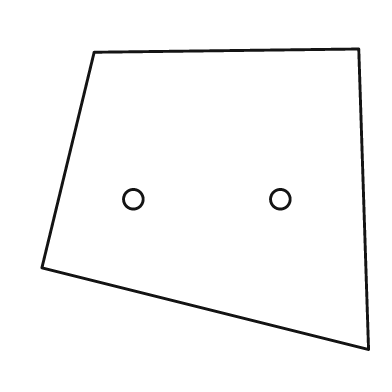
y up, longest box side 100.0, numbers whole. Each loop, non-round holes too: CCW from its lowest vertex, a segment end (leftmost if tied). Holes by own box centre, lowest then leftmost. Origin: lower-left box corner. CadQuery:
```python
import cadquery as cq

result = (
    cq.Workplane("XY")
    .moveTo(100.0, 0.0)
    .lineTo(97.0, 92.0)
    .lineTo(16.0, 91.0)
    .lineTo(0.0, 25.0)
    .close()
    .moveTo(28.0, 46.0)
    .circle(3.0)
    .moveTo(73.0, 46.0)
    .circle(3.0)
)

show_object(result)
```